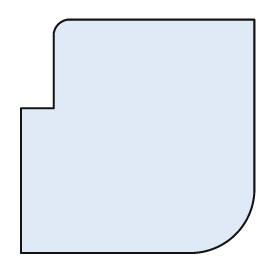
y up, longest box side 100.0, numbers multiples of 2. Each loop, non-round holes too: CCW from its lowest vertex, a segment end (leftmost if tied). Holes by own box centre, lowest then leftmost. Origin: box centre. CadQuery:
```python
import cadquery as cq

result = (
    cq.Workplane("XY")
    .moveTo(-50.0, -50.0)
    .lineTo(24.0, -50.0)
    .threePointArc((42.0, -42.0), (50.0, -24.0))
    .lineTo(50.0, 50.0)
    .lineTo(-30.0, 50.0)
    .threePointArc((-34.0, 48.0), (-36.0, 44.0))
    .lineTo(-36.0, 12.0)
    .lineTo(-50.0, 12.0)
    .close()
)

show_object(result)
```